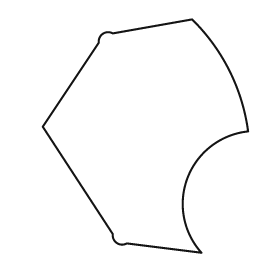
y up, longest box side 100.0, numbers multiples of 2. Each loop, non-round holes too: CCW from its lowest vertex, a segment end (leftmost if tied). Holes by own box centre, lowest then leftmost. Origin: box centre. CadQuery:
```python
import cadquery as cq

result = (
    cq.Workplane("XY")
    .moveTo(24.0, -50.0)
    .threePointArc((18.0, -18.0), (44.0, 2.0))
    .threePointArc((36.0, 28.0), (20.0, 50.0))
    .lineTo(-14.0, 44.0)
    .threePointArc((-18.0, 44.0), (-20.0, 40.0))
    .lineTo(-44.0, 4.0)
    .lineTo(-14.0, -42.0)
    .threePointArc((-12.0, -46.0), (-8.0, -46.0))
    .close()
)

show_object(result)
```